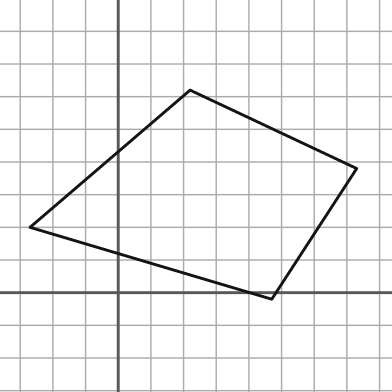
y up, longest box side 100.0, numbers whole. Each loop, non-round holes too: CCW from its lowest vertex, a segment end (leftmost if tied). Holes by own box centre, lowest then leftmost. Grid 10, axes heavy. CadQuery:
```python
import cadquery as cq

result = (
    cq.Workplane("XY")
    .moveTo(47.0, -2.0)
    .lineTo(73.0, 38.0)
    .lineTo(22.0, 62.0)
    .lineTo(-27.0, 20.0)
    .close()
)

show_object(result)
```